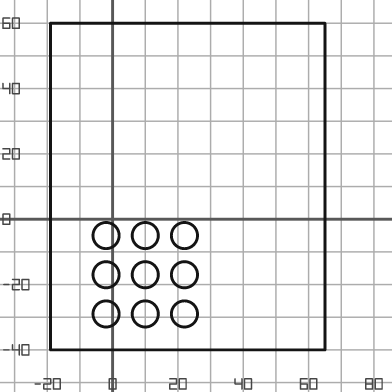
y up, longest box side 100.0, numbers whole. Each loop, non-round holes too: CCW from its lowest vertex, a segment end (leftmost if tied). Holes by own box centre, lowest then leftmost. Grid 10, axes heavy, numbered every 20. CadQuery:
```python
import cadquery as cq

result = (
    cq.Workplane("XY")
    .moveTo(-19.0, -40.0)
    .lineTo(65.0, -40.0)
    .lineTo(65.0, 60.0)
    .lineTo(-19.0, 60.0)
    .close()
    .moveTo(-2.0, -29.0)
    .circle(4.0)
    .moveTo(10.0, -29.0)
    .circle(4.0)
    .moveTo(22.0, -29.0)
    .circle(4.0)
    .moveTo(-2.0, -17.0)
    .circle(4.0)
    .moveTo(10.0, -17.0)
    .circle(4.0)
    .moveTo(22.0, -17.0)
    .circle(4.0)
    .moveTo(-2.0, -5.0)
    .circle(4.0)
    .moveTo(10.0, -5.0)
    .circle(4.0)
    .moveTo(22.0, -5.0)
    .circle(4.0)
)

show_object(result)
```